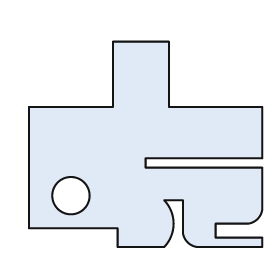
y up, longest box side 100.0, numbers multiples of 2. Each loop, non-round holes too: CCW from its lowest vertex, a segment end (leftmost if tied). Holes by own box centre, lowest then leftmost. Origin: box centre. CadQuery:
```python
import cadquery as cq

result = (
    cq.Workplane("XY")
    .moveTo(-12.0, -44.0)
    .lineTo(8.0, -44.0)
    .threePointArc((12.0, -34.0), (8.0, -24.0))
    .lineTo(16.0, -24.0)
    .lineTo(16.0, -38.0)
    .threePointArc((18.0, -42.0), (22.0, -44.0))
    .lineTo(50.0, -44.0)
    .lineTo(50.0, -40.0)
    .lineTo(30.0, -40.0)
    .lineTo(30.0, -34.0)
    .lineTo(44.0, -34.0)
    .threePointArc((48.0, -32.0), (50.0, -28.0))
    .lineTo(50.0, -10.0)
    .lineTo(0.0, -10.0)
    .lineTo(0.0, -6.0)
    .lineTo(50.0, -6.0)
    .lineTo(50.0, 16.0)
    .lineTo(10.0, 16.0)
    .lineTo(10.0, 44.0)
    .lineTo(-14.0, 44.0)
    .lineTo(-14.0, 16.0)
    .lineTo(-50.0, 16.0)
    .lineTo(-50.0, -36.0)
    .lineTo(-12.0, -36.0)
    .close()
    .moveTo(-32.0, -22.0)
    .circle(8.0)
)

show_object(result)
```